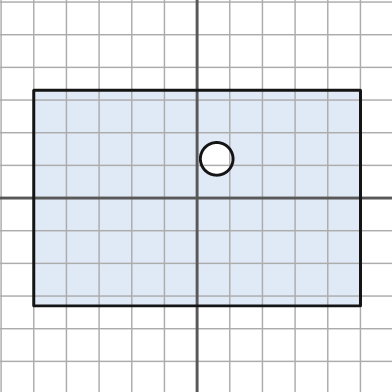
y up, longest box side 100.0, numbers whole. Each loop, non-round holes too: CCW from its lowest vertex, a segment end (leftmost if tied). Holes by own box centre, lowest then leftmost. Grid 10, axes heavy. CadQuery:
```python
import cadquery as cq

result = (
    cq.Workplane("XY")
    .moveTo(-50.0, -33.0)
    .lineTo(50.0, -33.0)
    .lineTo(50.0, 33.0)
    .lineTo(-50.0, 33.0)
    .close()
    .moveTo(6.0, 12.0)
    .circle(5.0)
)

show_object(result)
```